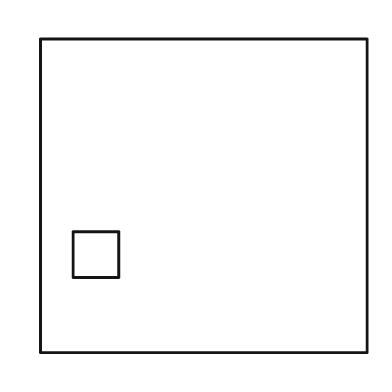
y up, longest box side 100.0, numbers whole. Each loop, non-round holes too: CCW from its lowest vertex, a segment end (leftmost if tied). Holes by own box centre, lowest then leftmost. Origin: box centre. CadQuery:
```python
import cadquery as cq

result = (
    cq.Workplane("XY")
    .moveTo(-50.0, -48.0)
    .lineTo(50.0, -48.0)
    .lineTo(50.0, 48.0)
    .lineTo(-50.0, 48.0)
    .close()
    .moveTo(-40.0, -25.0)
    .lineTo(-26.0, -25.0)
    .lineTo(-26.0, -11.0)
    .lineTo(-40.0, -11.0)
    .close()
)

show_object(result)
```